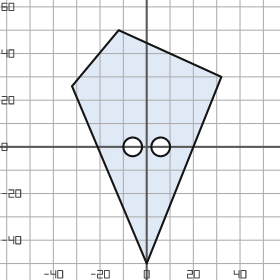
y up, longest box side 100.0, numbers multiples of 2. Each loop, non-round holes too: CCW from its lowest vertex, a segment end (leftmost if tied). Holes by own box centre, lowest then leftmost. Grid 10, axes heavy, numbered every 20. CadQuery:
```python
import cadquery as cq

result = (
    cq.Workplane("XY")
    .moveTo(0.0, -50.0)
    .lineTo(32.0, 30.0)
    .lineTo(-12.0, 50.0)
    .lineTo(-32.0, 26.0)
    .close()
    .moveTo(-6.0, 0.0)
    .circle(4.0)
    .moveTo(6.0, 0.0)
    .circle(4.0)
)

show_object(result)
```